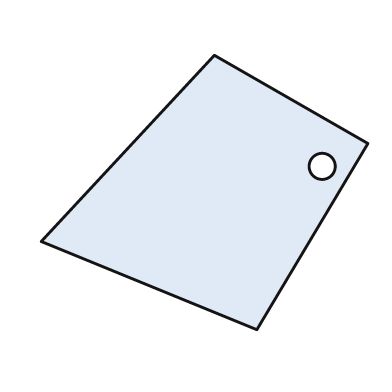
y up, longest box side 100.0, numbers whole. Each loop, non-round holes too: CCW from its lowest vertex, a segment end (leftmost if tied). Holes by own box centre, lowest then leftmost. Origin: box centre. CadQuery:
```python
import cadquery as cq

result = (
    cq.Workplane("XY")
    .moveTo(16.0, -42.0)
    .lineTo(50.0, 15.0)
    .lineTo(3.0, 42.0)
    .lineTo(-50.0, -15.0)
    .close()
    .moveTo(36.0, 8.0)
    .circle(4.0)
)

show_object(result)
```